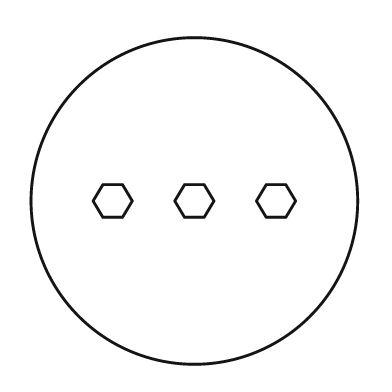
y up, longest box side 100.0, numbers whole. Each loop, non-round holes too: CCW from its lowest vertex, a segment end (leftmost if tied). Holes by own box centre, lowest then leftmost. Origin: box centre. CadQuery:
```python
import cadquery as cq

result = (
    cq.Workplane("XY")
    .moveTo(0.0, 0.0)
    .circle(50.0)
    .moveTo(-28.0, -5.0)
    .lineTo(-22.0, -5.0)
    .lineTo(-19.0, 0.0)
    .lineTo(-22.0, 5.0)
    .lineTo(-28.0, 5.0)
    .lineTo(-31.0, 0.0)
    .close()
    .moveTo(-3.0, -5.0)
    .lineTo(3.0, -5.0)
    .lineTo(6.0, 0.0)
    .lineTo(3.0, 5.0)
    .lineTo(-3.0, 5.0)
    .lineTo(-6.0, 0.0)
    .close()
    .moveTo(22.0, -5.0)
    .lineTo(28.0, -5.0)
    .lineTo(31.0, 0.0)
    .lineTo(28.0, 5.0)
    .lineTo(22.0, 5.0)
    .lineTo(19.0, 0.0)
    .close()
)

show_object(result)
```